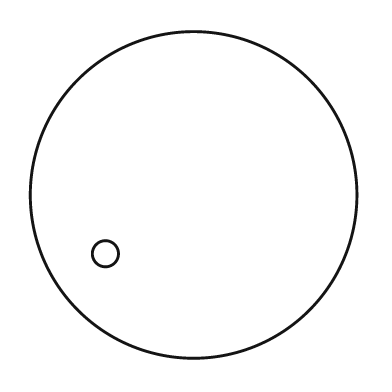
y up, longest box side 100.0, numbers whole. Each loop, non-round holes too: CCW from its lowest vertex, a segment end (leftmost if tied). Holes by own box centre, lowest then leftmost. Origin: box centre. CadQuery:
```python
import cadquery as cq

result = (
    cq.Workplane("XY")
    .moveTo(0.0, 0.0)
    .circle(50.0)
    .moveTo(-27.0, -18.0)
    .circle(4.0)
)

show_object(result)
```